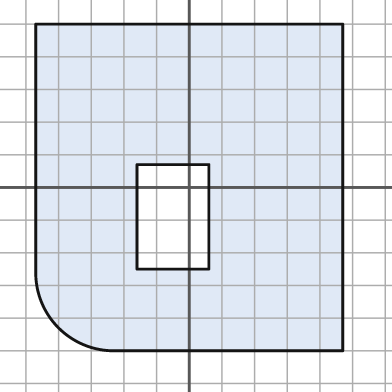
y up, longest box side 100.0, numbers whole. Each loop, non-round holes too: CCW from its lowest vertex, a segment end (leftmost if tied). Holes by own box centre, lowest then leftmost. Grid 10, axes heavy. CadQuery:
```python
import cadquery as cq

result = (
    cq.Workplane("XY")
    .moveTo(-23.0, -50.0)
    .lineTo(47.0, -50.0)
    .lineTo(47.0, 50.0)
    .lineTo(-47.0, 50.0)
    .lineTo(-47.0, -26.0)
    .threePointArc((-40.0, -43.0), (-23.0, -50.0))
    .close()
    .moveTo(-16.0, -25.0)
    .lineTo(6.0, -25.0)
    .lineTo(6.0, 7.0)
    .lineTo(-16.0, 7.0)
    .close()
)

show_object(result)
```